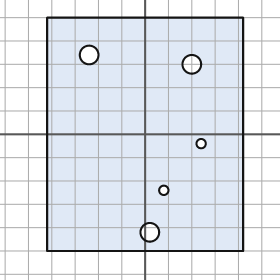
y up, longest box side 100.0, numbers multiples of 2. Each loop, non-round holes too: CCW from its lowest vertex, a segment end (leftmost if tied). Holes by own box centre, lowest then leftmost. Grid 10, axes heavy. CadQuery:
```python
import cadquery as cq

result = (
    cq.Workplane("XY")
    .moveTo(-42.0, -50.0)
    .lineTo(42.0, -50.0)
    .lineTo(42.0, 50.0)
    .lineTo(-42.0, 50.0)
    .close()
    .moveTo(2.0, -42.0)
    .circle(4.0)
    .moveTo(8.0, -24.0)
    .circle(2.0)
    .moveTo(24.0, -4.0)
    .circle(2.0)
    .moveTo(20.0, 30.0)
    .circle(4.0)
    .moveTo(-24.0, 34.0)
    .circle(4.0)
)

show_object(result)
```